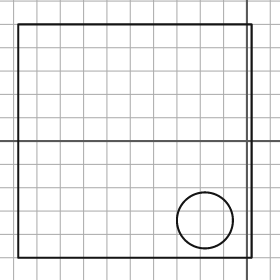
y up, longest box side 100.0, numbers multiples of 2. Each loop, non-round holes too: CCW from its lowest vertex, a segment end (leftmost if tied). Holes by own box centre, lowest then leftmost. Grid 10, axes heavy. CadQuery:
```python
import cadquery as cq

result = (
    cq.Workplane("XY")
    .moveTo(-98.0, -50.0)
    .lineTo(2.0, -50.0)
    .lineTo(2.0, 50.0)
    .lineTo(-98.0, 50.0)
    .close()
    .moveTo(-18.0, -34.0)
    .circle(12.0)
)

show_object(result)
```